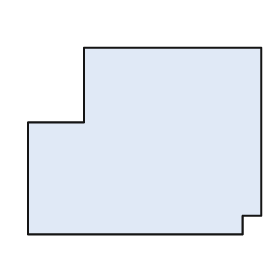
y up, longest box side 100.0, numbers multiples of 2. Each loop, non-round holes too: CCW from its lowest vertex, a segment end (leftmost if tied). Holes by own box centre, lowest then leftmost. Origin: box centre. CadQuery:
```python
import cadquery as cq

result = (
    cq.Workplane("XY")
    .moveTo(-50.0, -40.0)
    .lineTo(42.0, -40.0)
    .lineTo(42.0, -32.0)
    .lineTo(50.0, -32.0)
    .lineTo(50.0, 40.0)
    .lineTo(-26.0, 40.0)
    .lineTo(-26.0, 8.0)
    .lineTo(-50.0, 8.0)
    .close()
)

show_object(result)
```